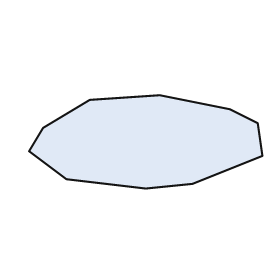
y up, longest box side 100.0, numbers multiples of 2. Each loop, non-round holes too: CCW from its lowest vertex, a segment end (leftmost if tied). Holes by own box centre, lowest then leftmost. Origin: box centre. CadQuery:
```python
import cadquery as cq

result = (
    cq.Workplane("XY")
    .moveTo(0.0, -20.0)
    .lineTo(20.0, -18.0)
    .lineTo(50.0, -6.0)
    .lineTo(48.0, 8.0)
    .lineTo(36.0, 14.0)
    .lineTo(6.0, 20.0)
    .lineTo(-24.0, 18.0)
    .lineTo(-44.0, 6.0)
    .lineTo(-50.0, -4.0)
    .lineTo(-34.0, -16.0)
    .close()
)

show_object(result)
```